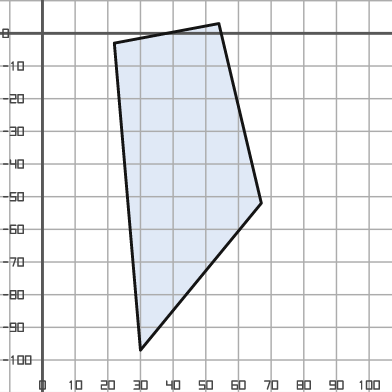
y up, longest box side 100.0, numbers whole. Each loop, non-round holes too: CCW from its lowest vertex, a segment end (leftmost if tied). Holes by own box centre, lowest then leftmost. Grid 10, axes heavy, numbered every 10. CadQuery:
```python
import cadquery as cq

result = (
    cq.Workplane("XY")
    .moveTo(30.0, -97.0)
    .lineTo(67.0, -52.0)
    .lineTo(54.0, 3.0)
    .lineTo(22.0, -3.0)
    .close()
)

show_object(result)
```